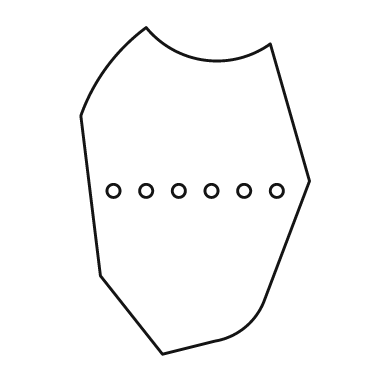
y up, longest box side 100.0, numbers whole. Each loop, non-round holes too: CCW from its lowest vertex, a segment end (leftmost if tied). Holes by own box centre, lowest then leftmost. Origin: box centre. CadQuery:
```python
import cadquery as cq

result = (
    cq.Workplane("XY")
    .moveTo(-10.0, -50.0)
    .lineTo(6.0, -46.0)
    .threePointArc((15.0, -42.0), (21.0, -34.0))
    .lineTo(35.0, 3.0)
    .lineTo(23.0, 45.0)
    .threePointArc((3.0, 40.0), (-15.0, 50.0))
    .threePointArc((-27.0, 38.0), (-35.0, 23.0))
    .lineTo(-29.0, -26.0)
    .close()
    .moveTo(-25.0, 0.0)
    .circle(2.0)
    .moveTo(-15.0, 0.0)
    .circle(2.0)
    .moveTo(-5.0, 0.0)
    .circle(2.0)
    .moveTo(5.0, 0.0)
    .circle(2.0)
    .moveTo(15.0, 0.0)
    .circle(2.0)
    .moveTo(25.0, 0.0)
    .circle(2.0)
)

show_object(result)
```